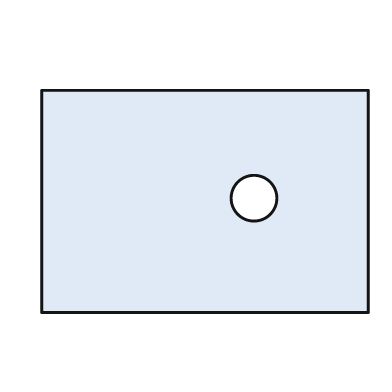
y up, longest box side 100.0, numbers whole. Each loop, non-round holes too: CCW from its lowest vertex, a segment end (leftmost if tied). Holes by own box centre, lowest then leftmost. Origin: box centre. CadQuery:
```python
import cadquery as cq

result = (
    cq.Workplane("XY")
    .moveTo(-50.0, -34.0)
    .lineTo(50.0, -34.0)
    .lineTo(50.0, 34.0)
    .lineTo(-50.0, 34.0)
    .close()
    .moveTo(15.0, 1.0)
    .circle(7.0)
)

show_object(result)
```